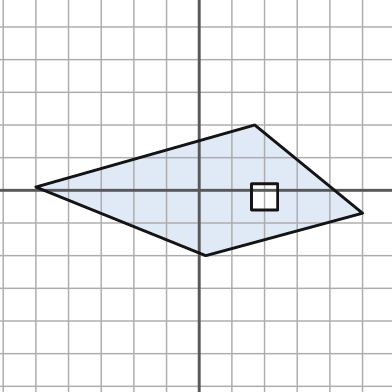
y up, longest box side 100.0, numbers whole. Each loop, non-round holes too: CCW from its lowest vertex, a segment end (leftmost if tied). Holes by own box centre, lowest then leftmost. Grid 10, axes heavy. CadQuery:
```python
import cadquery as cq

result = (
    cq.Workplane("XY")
    .moveTo(2.0, -20.0)
    .lineTo(50.0, -7.0)
    .lineTo(17.0, 20.0)
    .lineTo(-50.0, 1.0)
    .close()
    .moveTo(16.0, -6.0)
    .lineTo(24.0, -6.0)
    .lineTo(24.0, 2.0)
    .lineTo(16.0, 2.0)
    .close()
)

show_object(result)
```